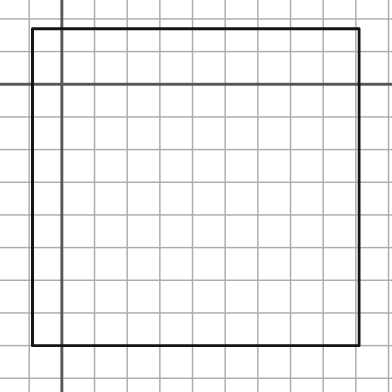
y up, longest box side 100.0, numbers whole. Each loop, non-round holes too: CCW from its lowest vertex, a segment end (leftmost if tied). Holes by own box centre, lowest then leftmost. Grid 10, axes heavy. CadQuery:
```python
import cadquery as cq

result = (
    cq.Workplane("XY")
    .moveTo(-9.0, -80.0)
    .lineTo(91.0, -80.0)
    .lineTo(91.0, 17.0)
    .lineTo(-9.0, 17.0)
    .close()
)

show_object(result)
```